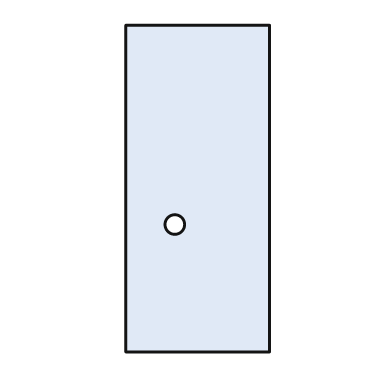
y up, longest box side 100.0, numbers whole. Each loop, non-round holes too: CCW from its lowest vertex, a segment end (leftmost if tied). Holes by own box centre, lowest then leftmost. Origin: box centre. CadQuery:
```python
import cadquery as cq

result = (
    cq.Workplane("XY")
    .moveTo(-22.0, -50.0)
    .lineTo(22.0, -50.0)
    .lineTo(22.0, 50.0)
    .lineTo(-22.0, 50.0)
    .close()
    .moveTo(-7.0, -11.0)
    .circle(3.0)
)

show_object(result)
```